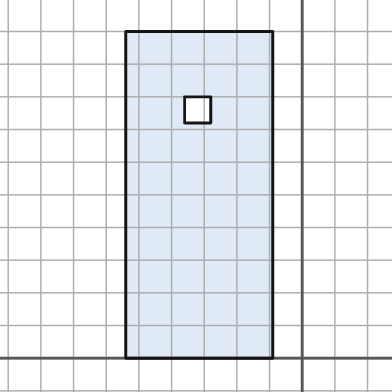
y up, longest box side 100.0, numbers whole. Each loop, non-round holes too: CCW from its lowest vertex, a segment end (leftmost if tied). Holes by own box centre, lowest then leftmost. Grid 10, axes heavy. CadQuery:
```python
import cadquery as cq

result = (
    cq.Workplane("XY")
    .moveTo(-54.0, 0.0)
    .lineTo(-9.0, 0.0)
    .lineTo(-9.0, 100.0)
    .lineTo(-54.0, 100.0)
    .close()
    .moveTo(-36.0, 72.0)
    .lineTo(-28.0, 72.0)
    .lineTo(-28.0, 80.0)
    .lineTo(-36.0, 80.0)
    .close()
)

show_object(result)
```